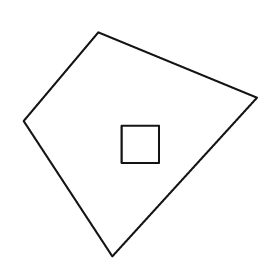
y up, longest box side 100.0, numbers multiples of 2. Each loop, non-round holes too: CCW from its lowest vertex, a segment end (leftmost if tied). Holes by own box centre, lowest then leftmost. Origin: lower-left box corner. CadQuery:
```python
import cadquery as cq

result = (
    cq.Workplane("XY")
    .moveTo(38.0, 0.0)
    .lineTo(100.0, 68.0)
    .lineTo(32.0, 96.0)
    .lineTo(0.0, 58.0)
    .close()
    .moveTo(42.0, 40.0)
    .lineTo(58.0, 40.0)
    .lineTo(58.0, 56.0)
    .lineTo(42.0, 56.0)
    .close()
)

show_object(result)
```